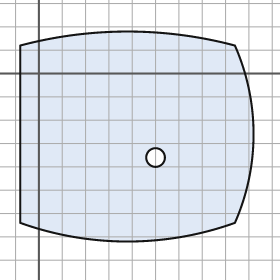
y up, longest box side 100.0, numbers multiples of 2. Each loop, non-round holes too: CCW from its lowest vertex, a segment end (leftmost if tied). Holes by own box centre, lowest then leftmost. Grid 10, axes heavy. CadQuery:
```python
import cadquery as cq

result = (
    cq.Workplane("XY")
    .moveTo(-8.0, -64.0)
    .threePointArc((38.0, -72.0), (84.0, -64.0))
    .threePointArc((92.0, -26.0), (84.0, 12.0))
    .threePointArc((38.0, 18.0), (-8.0, 12.0))
    .close()
    .moveTo(50.0, -36.0)
    .circle(4.0)
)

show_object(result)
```